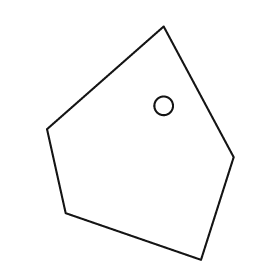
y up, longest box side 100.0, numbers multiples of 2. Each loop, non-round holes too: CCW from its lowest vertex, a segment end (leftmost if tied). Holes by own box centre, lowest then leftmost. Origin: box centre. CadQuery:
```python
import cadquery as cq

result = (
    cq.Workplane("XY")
    .moveTo(26.0, -50.0)
    .lineTo(40.0, -6.0)
    .lineTo(10.0, 50.0)
    .lineTo(-40.0, 6.0)
    .lineTo(-32.0, -30.0)
    .close()
    .moveTo(10.0, 16.0)
    .circle(4.0)
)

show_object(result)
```